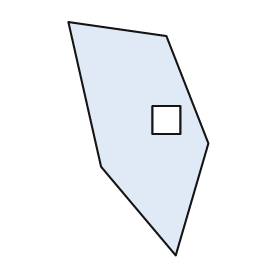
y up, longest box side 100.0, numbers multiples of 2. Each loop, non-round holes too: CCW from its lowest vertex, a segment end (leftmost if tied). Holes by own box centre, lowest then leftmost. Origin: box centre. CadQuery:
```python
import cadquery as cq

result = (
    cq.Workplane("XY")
    .moveTo(16.0, -50.0)
    .lineTo(30.0, -2.0)
    .lineTo(12.0, 44.0)
    .lineTo(-30.0, 50.0)
    .lineTo(-16.0, -12.0)
    .close()
    .moveTo(6.0, 2.0)
    .lineTo(18.0, 2.0)
    .lineTo(18.0, 14.0)
    .lineTo(6.0, 14.0)
    .close()
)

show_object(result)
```